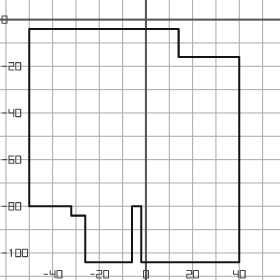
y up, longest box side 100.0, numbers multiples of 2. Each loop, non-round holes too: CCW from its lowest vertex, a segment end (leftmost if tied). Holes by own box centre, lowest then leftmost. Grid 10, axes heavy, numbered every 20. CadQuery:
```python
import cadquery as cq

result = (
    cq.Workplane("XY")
    .moveTo(-26.0, -104.0)
    .lineTo(-6.0, -104.0)
    .lineTo(-6.0, -80.0)
    .lineTo(-2.0, -80.0)
    .lineTo(-2.0, -104.0)
    .lineTo(40.0, -104.0)
    .lineTo(40.0, -16.0)
    .lineTo(14.0, -16.0)
    .lineTo(14.0, -4.0)
    .lineTo(-50.0, -4.0)
    .lineTo(-50.0, -80.0)
    .lineTo(-32.0, -80.0)
    .lineTo(-32.0, -84.0)
    .lineTo(-26.0, -84.0)
    .close()
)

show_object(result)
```